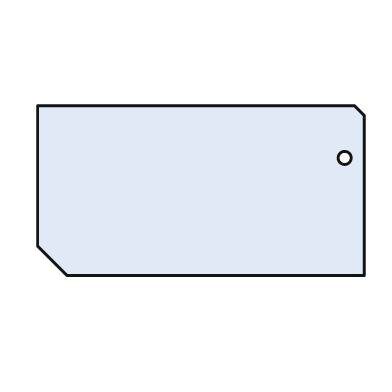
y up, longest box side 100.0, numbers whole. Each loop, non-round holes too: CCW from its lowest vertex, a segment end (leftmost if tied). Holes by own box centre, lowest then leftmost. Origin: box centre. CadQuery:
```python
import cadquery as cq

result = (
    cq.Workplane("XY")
    .moveTo(-41.0, -26.0)
    .lineTo(50.0, -26.0)
    .lineTo(50.0, 23.0)
    .lineTo(47.0, 26.0)
    .lineTo(-50.0, 26.0)
    .lineTo(-50.0, -17.0)
    .close()
    .moveTo(44.0, 10.0)
    .circle(2.0)
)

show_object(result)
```